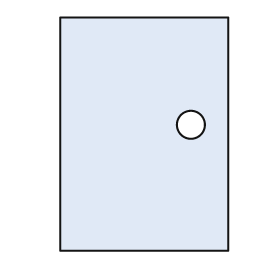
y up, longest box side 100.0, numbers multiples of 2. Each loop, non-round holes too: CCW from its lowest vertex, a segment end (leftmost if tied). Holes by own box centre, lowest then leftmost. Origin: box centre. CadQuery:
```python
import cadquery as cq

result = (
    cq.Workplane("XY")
    .moveTo(-36.0, -50.0)
    .lineTo(36.0, -50.0)
    .lineTo(36.0, 50.0)
    .lineTo(-36.0, 50.0)
    .close()
    .moveTo(20.0, 4.0)
    .circle(6.0)
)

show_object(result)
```